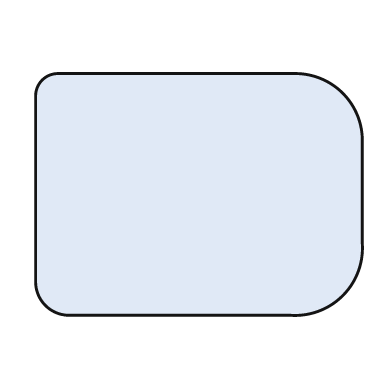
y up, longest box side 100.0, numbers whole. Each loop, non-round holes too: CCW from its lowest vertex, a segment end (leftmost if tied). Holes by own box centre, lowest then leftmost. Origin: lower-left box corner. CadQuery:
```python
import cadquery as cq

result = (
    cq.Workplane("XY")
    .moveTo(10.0, 0.0)
    .lineTo(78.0, 0.0)
    .threePointArc((94.0, 6.0), (100.0, 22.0))
    .lineTo(100.0, 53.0)
    .threePointArc((94.0, 68.0), (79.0, 74.0))
    .lineTo(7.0, 74.0)
    .threePointArc((2.0, 72.0), (0.0, 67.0))
    .lineTo(0.0, 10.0)
    .threePointArc((3.0, 3.0), (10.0, 0.0))
    .close()
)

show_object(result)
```